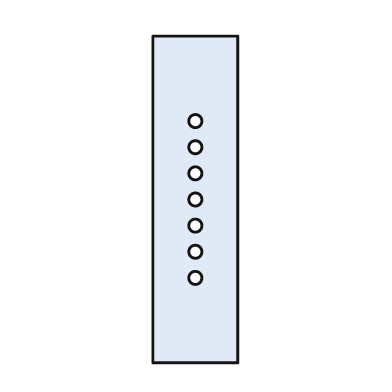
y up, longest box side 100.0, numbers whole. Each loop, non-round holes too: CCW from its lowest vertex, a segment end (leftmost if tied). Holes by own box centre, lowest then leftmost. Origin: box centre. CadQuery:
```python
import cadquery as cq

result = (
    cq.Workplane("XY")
    .moveTo(-13.0, -50.0)
    .lineTo(13.0, -50.0)
    .lineTo(13.0, 50.0)
    .lineTo(-13.0, 50.0)
    .close()
    .moveTo(0.0, -24.0)
    .circle(2.0)
    .moveTo(0.0, -16.0)
    .circle(2.0)
    .moveTo(0.0, -8.0)
    .circle(2.0)
    .moveTo(0.0, 0.0)
    .circle(2.0)
    .moveTo(0.0, 8.0)
    .circle(2.0)
    .moveTo(0.0, 16.0)
    .circle(2.0)
    .moveTo(0.0, 24.0)
    .circle(2.0)
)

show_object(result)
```